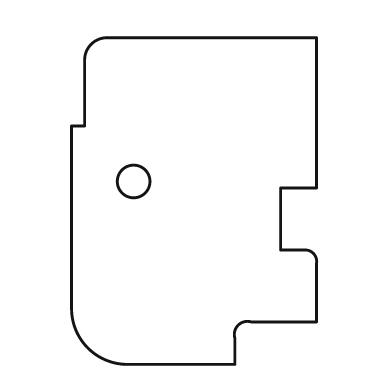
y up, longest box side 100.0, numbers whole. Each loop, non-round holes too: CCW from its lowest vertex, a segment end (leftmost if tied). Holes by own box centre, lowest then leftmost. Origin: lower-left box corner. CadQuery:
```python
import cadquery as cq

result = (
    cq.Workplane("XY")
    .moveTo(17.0, 0.0)
    .lineTo(50.0, 0.0)
    .lineTo(50.0, 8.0)
    .threePointArc((51.0, 12.0), (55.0, 13.0))
    .lineTo(75.0, 13.0)
    .lineTo(75.0, 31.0)
    .threePointArc((74.0, 34.0), (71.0, 35.0))
    .lineTo(64.0, 35.0)
    .lineTo(64.0, 54.0)
    .lineTo(75.0, 54.0)
    .lineTo(75.0, 100.0)
    .lineTo(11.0, 100.0)
    .threePointArc((6.0, 98.0), (4.0, 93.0))
    .lineTo(4.0, 73.0)
    .lineTo(0.0, 73.0)
    .lineTo(0.0, 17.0)
    .threePointArc((5.0, 5.0), (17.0, 0.0))
    .close()
    .moveTo(19.0, 56.0)
    .circle(5.0)
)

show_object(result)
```